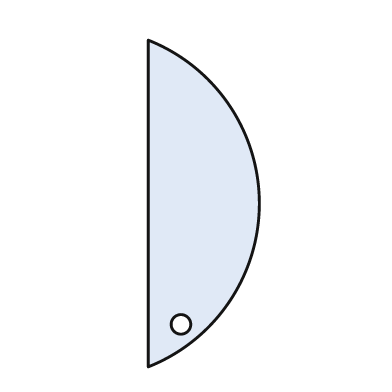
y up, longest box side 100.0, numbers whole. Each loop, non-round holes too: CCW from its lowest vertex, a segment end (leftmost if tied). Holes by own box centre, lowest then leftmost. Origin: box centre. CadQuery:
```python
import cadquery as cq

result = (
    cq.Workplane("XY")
    .moveTo(-17.0, -50.0)
    .threePointArc((17.0, 0.0), (-17.0, 50.0))
    .close()
    .moveTo(-7.0, -37.0)
    .circle(3.0)
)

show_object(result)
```